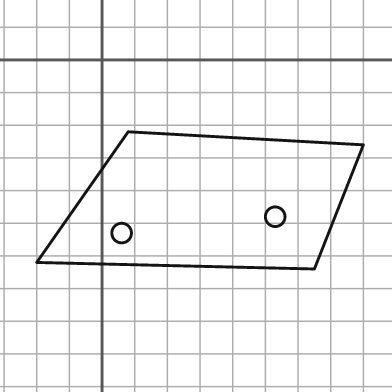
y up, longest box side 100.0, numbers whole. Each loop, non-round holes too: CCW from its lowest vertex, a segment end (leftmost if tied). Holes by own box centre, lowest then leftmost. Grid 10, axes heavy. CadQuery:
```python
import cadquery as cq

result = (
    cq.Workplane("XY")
    .moveTo(65.0, -64.0)
    .lineTo(80.0, -26.0)
    .lineTo(8.0, -22.0)
    .lineTo(-20.0, -62.0)
    .close()
    .moveTo(6.0, -53.0)
    .circle(3.0)
    .moveTo(53.0, -48.0)
    .circle(3.0)
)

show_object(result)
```